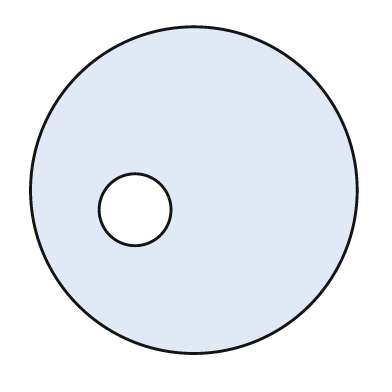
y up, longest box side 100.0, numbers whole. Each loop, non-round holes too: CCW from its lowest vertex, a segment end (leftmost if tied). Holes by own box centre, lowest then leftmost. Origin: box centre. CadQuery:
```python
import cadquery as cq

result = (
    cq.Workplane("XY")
    .moveTo(0.0, 0.0)
    .circle(50.0)
    .moveTo(-18.0, -6.0)
    .circle(11.0)
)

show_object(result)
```